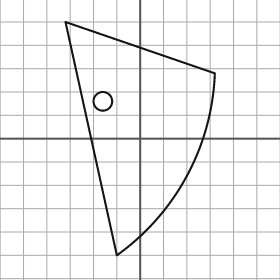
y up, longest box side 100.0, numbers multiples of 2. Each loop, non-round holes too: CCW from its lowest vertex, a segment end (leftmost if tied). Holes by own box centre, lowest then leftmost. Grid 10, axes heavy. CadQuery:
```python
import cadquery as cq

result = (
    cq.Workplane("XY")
    .moveTo(-10.0, -50.0)
    .threePointArc((20.0, -16.0), (32.0, 28.0))
    .lineTo(-32.0, 50.0)
    .close()
    .moveTo(-16.0, 16.0)
    .circle(4.0)
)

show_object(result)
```